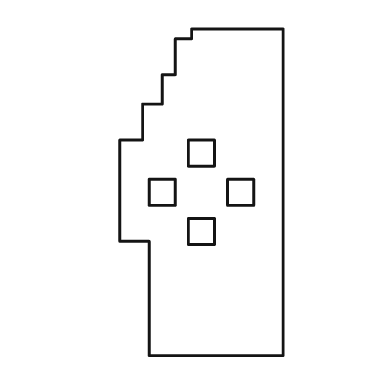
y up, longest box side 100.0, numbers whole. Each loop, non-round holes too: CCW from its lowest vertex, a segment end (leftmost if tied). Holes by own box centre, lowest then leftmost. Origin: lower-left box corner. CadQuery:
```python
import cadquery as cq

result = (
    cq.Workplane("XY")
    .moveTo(9.0, 0.0)
    .lineTo(50.0, 0.0)
    .lineTo(50.0, 100.0)
    .lineTo(22.0, 100.0)
    .lineTo(22.0, 97.0)
    .lineTo(17.0, 97.0)
    .lineTo(17.0, 86.0)
    .lineTo(13.0, 86.0)
    .lineTo(13.0, 77.0)
    .lineTo(7.0, 77.0)
    .lineTo(7.0, 66.0)
    .lineTo(0.0, 66.0)
    .lineTo(0.0, 35.0)
    .lineTo(9.0, 35.0)
    .close()
    .moveTo(21.0, 34.0)
    .lineTo(29.0, 34.0)
    .lineTo(29.0, 42.0)
    .lineTo(21.0, 42.0)
    .close()
    .moveTo(9.0, 46.0)
    .lineTo(17.0, 46.0)
    .lineTo(17.0, 54.0)
    .lineTo(9.0, 54.0)
    .close()
    .moveTo(33.0, 46.0)
    .lineTo(41.0, 46.0)
    .lineTo(41.0, 54.0)
    .lineTo(33.0, 54.0)
    .close()
    .moveTo(21.0, 58.0)
    .lineTo(29.0, 58.0)
    .lineTo(29.0, 66.0)
    .lineTo(21.0, 66.0)
    .close()
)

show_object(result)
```